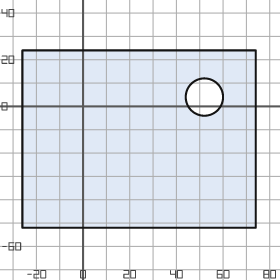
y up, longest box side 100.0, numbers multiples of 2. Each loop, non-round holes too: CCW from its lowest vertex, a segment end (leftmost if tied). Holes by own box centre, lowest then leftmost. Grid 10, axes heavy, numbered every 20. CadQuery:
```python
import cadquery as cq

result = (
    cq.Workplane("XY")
    .moveTo(-26.0, -52.0)
    .lineTo(74.0, -52.0)
    .lineTo(74.0, 24.0)
    .lineTo(-26.0, 24.0)
    .close()
    .moveTo(52.0, 4.0)
    .circle(8.0)
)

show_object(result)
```